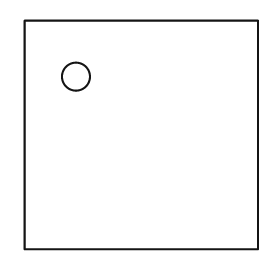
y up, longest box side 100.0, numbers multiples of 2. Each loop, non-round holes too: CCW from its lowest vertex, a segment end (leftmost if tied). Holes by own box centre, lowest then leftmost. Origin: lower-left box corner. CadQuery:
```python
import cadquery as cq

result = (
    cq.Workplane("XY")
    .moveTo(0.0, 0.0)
    .lineTo(100.0, 0.0)
    .lineTo(100.0, 98.0)
    .lineTo(0.0, 98.0)
    .close()
    .moveTo(22.0, 74.0)
    .circle(6.0)
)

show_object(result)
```